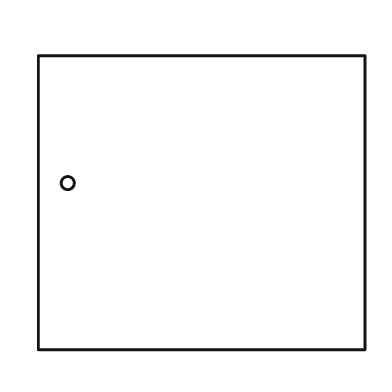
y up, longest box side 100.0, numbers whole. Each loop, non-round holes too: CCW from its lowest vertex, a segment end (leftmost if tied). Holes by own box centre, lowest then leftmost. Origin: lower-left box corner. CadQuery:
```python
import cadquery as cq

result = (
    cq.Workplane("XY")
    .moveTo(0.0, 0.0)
    .lineTo(100.0, 0.0)
    .lineTo(100.0, 90.0)
    .lineTo(0.0, 90.0)
    .close()
    .moveTo(9.0, 51.0)
    .circle(2.0)
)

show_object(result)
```